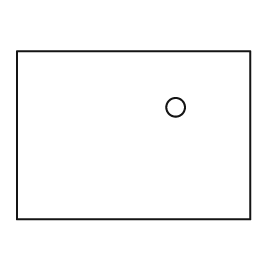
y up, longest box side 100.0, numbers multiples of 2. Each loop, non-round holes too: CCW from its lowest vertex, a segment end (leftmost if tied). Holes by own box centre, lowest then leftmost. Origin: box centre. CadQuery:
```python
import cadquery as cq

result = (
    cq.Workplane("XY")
    .moveTo(-50.0, -36.0)
    .lineTo(50.0, -36.0)
    .lineTo(50.0, 36.0)
    .lineTo(-50.0, 36.0)
    .close()
    .moveTo(18.0, 12.0)
    .circle(4.0)
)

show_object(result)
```